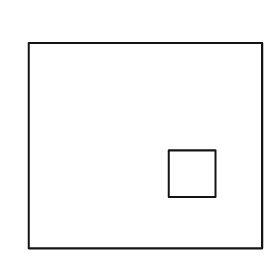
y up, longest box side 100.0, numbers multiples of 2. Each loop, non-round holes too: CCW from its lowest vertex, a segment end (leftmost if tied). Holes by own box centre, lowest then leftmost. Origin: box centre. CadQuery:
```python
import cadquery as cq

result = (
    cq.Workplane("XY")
    .moveTo(-50.0, -44.0)
    .lineTo(50.0, -44.0)
    .lineTo(50.0, 44.0)
    .lineTo(-50.0, 44.0)
    .close()
    .moveTo(10.0, -22.0)
    .lineTo(30.0, -22.0)
    .lineTo(30.0, -2.0)
    .lineTo(10.0, -2.0)
    .close()
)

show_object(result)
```